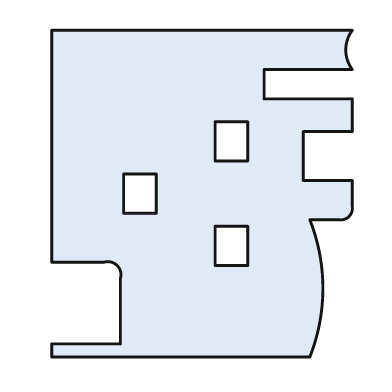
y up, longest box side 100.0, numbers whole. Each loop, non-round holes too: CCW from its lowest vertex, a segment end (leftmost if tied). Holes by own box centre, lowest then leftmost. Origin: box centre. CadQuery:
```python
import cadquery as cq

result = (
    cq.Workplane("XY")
    .moveTo(-46.0, -50.0)
    .lineTo(33.0, -50.0)
    .threePointArc((37.0, -29.0), (33.0, -8.0))
    .lineTo(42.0, -8.0)
    .threePointArc((45.0, -7.0), (46.0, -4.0))
    .lineTo(46.0, 4.0)
    .lineTo(31.0, 4.0)
    .lineTo(31.0, 19.0)
    .lineTo(46.0, 19.0)
    .lineTo(46.0, 29.0)
    .lineTo(19.0, 29.0)
    .lineTo(19.0, 38.0)
    .lineTo(46.0, 38.0)
    .threePointArc((44.0, 44.0), (46.0, 50.0))
    .lineTo(-46.0, 50.0)
    .lineTo(-46.0, -21.0)
    .lineTo(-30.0, -21.0)
    .threePointArc((-26.0, -22.0), (-25.0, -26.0))
    .lineTo(-25.0, -46.0)
    .lineTo(-46.0, -46.0)
    .close()
    .moveTo(4.0, -22.0)
    .lineTo(14.0, -22.0)
    .lineTo(14.0, -10.0)
    .lineTo(4.0, -10.0)
    .close()
    .moveTo(-24.0, -6.0)
    .lineTo(-14.0, -6.0)
    .lineTo(-14.0, 6.0)
    .lineTo(-24.0, 6.0)
    .close()
    .moveTo(4.0, 10.0)
    .lineTo(14.0, 10.0)
    .lineTo(14.0, 22.0)
    .lineTo(4.0, 22.0)
    .close()
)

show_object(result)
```